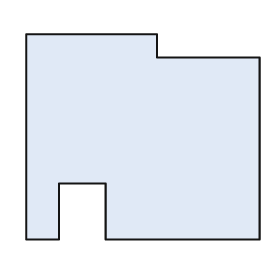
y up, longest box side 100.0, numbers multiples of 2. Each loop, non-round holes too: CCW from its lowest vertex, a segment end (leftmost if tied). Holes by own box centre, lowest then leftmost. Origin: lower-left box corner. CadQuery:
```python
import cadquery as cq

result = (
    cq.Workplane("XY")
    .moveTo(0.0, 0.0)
    .lineTo(14.0, 0.0)
    .lineTo(14.0, 24.0)
    .lineTo(34.0, 24.0)
    .lineTo(34.0, 0.0)
    .lineTo(100.0, 0.0)
    .lineTo(100.0, 78.0)
    .lineTo(56.0, 78.0)
    .lineTo(56.0, 88.0)
    .lineTo(0.0, 88.0)
    .close()
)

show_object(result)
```